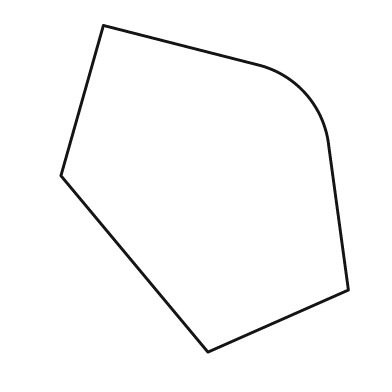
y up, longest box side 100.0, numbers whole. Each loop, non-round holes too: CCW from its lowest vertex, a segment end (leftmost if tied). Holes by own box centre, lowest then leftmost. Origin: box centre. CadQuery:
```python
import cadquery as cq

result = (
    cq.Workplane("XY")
    .moveTo(1.0, -50.0)
    .lineTo(44.0, -31.0)
    .lineTo(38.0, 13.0)
    .threePointArc((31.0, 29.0), (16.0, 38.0))
    .lineTo(-31.0, 50.0)
    .lineTo(-44.0, 4.0)
    .close()
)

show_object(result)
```